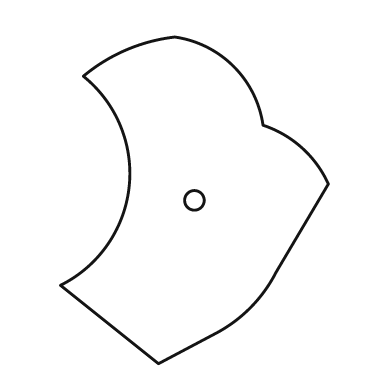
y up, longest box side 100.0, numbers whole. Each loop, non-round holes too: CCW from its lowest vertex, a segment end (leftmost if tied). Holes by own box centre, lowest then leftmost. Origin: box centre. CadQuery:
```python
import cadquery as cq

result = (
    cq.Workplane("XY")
    .moveTo(-11.0, -50.0)
    .lineTo(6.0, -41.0)
    .threePointArc((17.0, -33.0), (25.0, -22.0))
    .lineTo(41.0, 5.0)
    .threePointArc((33.0, 16.0), (21.0, 23.0))
    .threePointArc((12.0, 41.0), (-6.0, 50.0))
    .threePointArc((-21.0, 46.0), (-34.0, 38.0))
    .threePointArc((-20.0, 4.0), (-41.0, -26.0))
    .close()
    .moveTo(0.0, 0.0)
    .circle(3.0)
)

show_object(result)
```